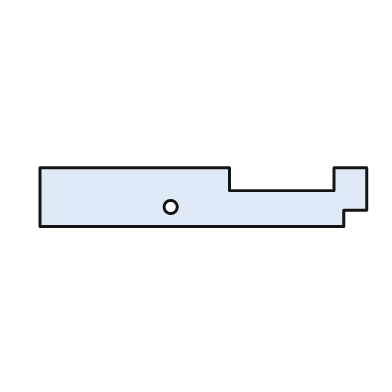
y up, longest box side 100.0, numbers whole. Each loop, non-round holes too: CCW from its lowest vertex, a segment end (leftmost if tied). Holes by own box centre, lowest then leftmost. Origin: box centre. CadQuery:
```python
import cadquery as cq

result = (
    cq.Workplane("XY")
    .moveTo(-50.0, -9.0)
    .lineTo(43.0, -9.0)
    .lineTo(43.0, -4.0)
    .lineTo(50.0, -4.0)
    .lineTo(50.0, 9.0)
    .lineTo(40.0, 9.0)
    .lineTo(40.0, 2.0)
    .lineTo(8.0, 2.0)
    .lineTo(8.0, 9.0)
    .lineTo(-50.0, 9.0)
    .close()
    .moveTo(-10.0, -3.0)
    .circle(2.0)
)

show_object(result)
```